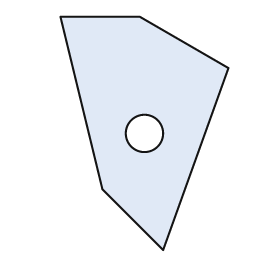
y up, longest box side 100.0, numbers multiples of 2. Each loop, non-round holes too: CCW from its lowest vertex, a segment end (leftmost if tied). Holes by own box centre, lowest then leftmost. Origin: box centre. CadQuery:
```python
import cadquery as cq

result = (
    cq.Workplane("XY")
    .moveTo(8.0, -50.0)
    .lineTo(36.0, 28.0)
    .lineTo(-2.0, 50.0)
    .lineTo(-36.0, 50.0)
    .lineTo(-18.0, -24.0)
    .close()
    .moveTo(0.0, 0.0)
    .circle(8.0)
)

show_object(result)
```